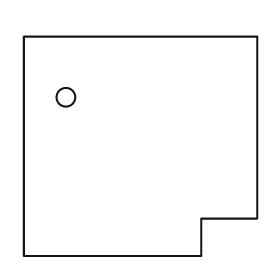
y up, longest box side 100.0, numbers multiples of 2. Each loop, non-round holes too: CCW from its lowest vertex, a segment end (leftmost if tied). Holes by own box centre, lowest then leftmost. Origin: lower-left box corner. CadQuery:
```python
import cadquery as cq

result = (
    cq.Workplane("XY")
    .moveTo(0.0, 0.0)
    .lineTo(76.0, 0.0)
    .lineTo(76.0, 16.0)
    .lineTo(100.0, 16.0)
    .lineTo(100.0, 94.0)
    .lineTo(0.0, 94.0)
    .close()
    .moveTo(18.0, 68.0)
    .circle(4.0)
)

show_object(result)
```